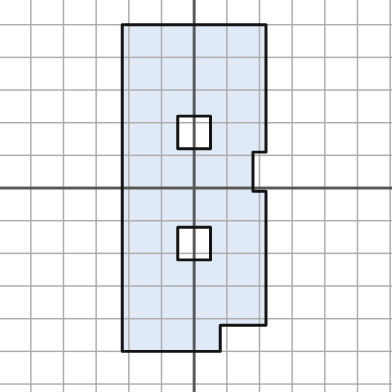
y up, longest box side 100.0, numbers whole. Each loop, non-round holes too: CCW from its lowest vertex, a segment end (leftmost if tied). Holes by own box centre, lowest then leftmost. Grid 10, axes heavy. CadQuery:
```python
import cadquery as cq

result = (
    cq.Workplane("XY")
    .moveTo(-22.0, -50.0)
    .lineTo(8.0, -50.0)
    .lineTo(8.0, -42.0)
    .lineTo(22.0, -42.0)
    .lineTo(22.0, -1.0)
    .lineTo(18.0, -1.0)
    .lineTo(18.0, 11.0)
    .lineTo(22.0, 11.0)
    .lineTo(22.0, 50.0)
    .lineTo(-22.0, 50.0)
    .close()
    .moveTo(-5.0, -22.0)
    .lineTo(5.0, -22.0)
    .lineTo(5.0, -12.0)
    .lineTo(-5.0, -12.0)
    .close()
    .moveTo(-5.0, 12.0)
    .lineTo(5.0, 12.0)
    .lineTo(5.0, 22.0)
    .lineTo(-5.0, 22.0)
    .close()
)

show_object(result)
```